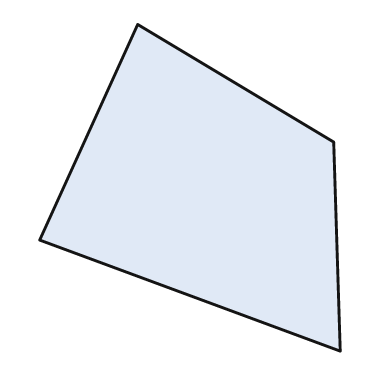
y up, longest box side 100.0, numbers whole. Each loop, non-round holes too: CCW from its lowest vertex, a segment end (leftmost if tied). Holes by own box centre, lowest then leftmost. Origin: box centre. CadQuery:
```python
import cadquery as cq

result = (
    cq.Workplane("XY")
    .moveTo(46.0, -50.0)
    .lineTo(44.0, 14.0)
    .lineTo(-16.0, 50.0)
    .lineTo(-46.0, -16.0)
    .close()
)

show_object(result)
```